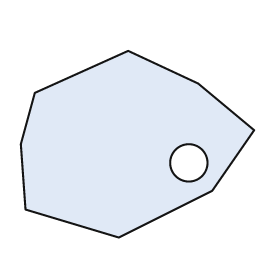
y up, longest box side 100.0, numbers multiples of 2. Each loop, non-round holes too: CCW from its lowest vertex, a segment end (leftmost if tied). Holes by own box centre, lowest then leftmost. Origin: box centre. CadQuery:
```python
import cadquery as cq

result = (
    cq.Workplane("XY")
    .moveTo(-8.0, -40.0)
    .lineTo(32.0, -20.0)
    .lineTo(50.0, 6.0)
    .lineTo(26.0, 26.0)
    .lineTo(-4.0, 40.0)
    .lineTo(-44.0, 22.0)
    .lineTo(-50.0, 0.0)
    .lineTo(-48.0, -28.0)
    .close()
    .moveTo(22.0, -8.0)
    .circle(8.0)
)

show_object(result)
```